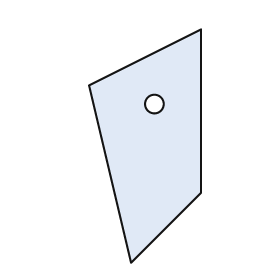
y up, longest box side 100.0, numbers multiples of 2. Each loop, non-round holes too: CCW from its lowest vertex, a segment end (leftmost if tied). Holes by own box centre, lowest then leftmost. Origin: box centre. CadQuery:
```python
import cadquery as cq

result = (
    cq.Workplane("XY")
    .moveTo(-6.0, -50.0)
    .lineTo(24.0, -20.0)
    .lineTo(24.0, 50.0)
    .lineTo(-24.0, 26.0)
    .close()
    .moveTo(4.0, 18.0)
    .circle(4.0)
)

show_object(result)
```